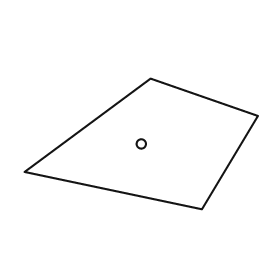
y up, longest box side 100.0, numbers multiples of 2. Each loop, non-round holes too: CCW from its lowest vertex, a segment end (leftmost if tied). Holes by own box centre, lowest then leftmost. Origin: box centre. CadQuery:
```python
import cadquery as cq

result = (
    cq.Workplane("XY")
    .moveTo(26.0, -28.0)
    .lineTo(50.0, 12.0)
    .lineTo(4.0, 28.0)
    .lineTo(-50.0, -12.0)
    .close()
    .moveTo(0.0, 0.0)
    .circle(2.0)
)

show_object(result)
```